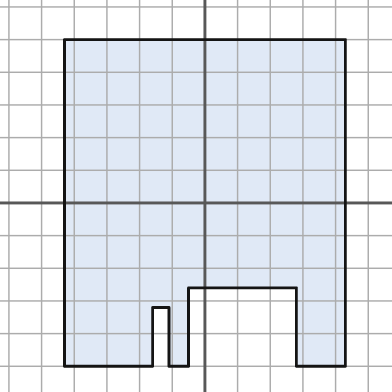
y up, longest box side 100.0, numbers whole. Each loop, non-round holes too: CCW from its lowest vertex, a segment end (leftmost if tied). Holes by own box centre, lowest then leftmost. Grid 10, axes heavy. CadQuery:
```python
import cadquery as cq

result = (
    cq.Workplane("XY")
    .moveTo(-43.0, -50.0)
    .lineTo(-16.0, -50.0)
    .lineTo(-16.0, -32.0)
    .lineTo(-11.0, -32.0)
    .lineTo(-11.0, -50.0)
    .lineTo(-5.0, -50.0)
    .lineTo(-5.0, -26.0)
    .lineTo(28.0, -26.0)
    .lineTo(28.0, -50.0)
    .lineTo(43.0, -50.0)
    .lineTo(43.0, 50.0)
    .lineTo(-43.0, 50.0)
    .close()
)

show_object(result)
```